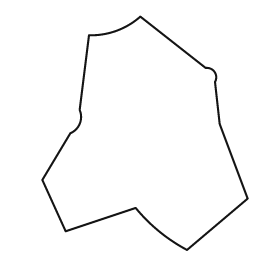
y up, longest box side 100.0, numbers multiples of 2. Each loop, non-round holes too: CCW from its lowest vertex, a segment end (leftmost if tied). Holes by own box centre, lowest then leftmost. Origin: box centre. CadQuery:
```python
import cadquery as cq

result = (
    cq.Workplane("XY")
    .moveTo(18.0, -50.0)
    .lineTo(44.0, -28.0)
    .lineTo(32.0, 4.0)
    .lineTo(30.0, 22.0)
    .threePointArc((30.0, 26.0), (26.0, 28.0))
    .lineTo(-2.0, 50.0)
    .threePointArc((-12.0, 44.0), (-24.0, 42.0))
    .lineTo(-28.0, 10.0)
    .threePointArc((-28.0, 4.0), (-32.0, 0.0))
    .lineTo(-44.0, -20.0)
    .lineTo(-34.0, -42.0)
    .lineTo(-4.0, -32.0)
    .threePointArc((6.0, -42.0), (18.0, -50.0))
    .close()
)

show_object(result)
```